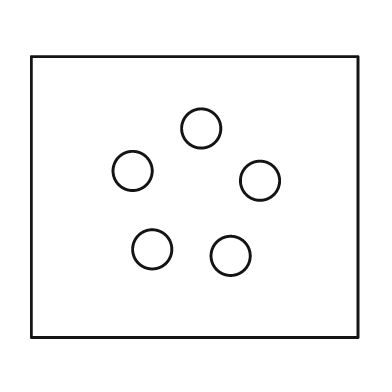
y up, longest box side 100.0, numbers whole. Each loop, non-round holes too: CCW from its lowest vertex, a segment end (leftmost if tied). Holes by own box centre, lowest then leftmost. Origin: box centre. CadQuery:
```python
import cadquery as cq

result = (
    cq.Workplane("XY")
    .moveTo(-50.0, -43.0)
    .lineTo(50.0, -43.0)
    .lineTo(50.0, 43.0)
    .lineTo(-50.0, 43.0)
    .close()
    .moveTo(11.0, -18.0)
    .circle(6.0)
    .moveTo(-13.0, -16.0)
    .circle(6.0)
    .moveTo(20.0, 5.0)
    .circle(6.0)
    .moveTo(-19.0, 8.0)
    .circle(6.0)
    .moveTo(2.0, 21.0)
    .circle(6.0)
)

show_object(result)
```